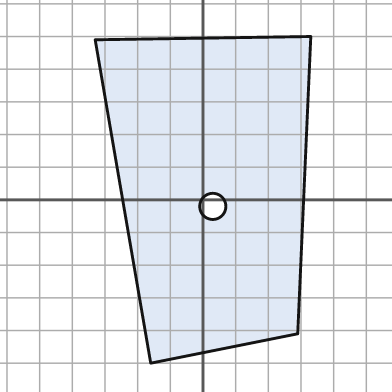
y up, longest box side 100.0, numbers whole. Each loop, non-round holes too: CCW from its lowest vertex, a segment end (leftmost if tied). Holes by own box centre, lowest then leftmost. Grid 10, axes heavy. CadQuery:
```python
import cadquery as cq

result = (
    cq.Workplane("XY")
    .moveTo(-16.0, -50.0)
    .lineTo(29.0, -41.0)
    .lineTo(33.0, 50.0)
    .lineTo(-33.0, 49.0)
    .close()
    .moveTo(3.0, -2.0)
    .circle(4.0)
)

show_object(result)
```